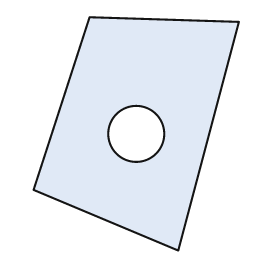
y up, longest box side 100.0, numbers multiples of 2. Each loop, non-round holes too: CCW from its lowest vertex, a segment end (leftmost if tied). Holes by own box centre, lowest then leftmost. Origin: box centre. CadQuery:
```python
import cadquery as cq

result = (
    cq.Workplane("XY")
    .moveTo(18.0, -50.0)
    .lineTo(44.0, 48.0)
    .lineTo(-20.0, 50.0)
    .lineTo(-44.0, -24.0)
    .close()
    .moveTo(0.0, 0.0)
    .circle(12.0)
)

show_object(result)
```